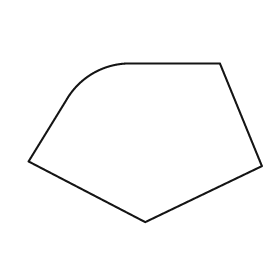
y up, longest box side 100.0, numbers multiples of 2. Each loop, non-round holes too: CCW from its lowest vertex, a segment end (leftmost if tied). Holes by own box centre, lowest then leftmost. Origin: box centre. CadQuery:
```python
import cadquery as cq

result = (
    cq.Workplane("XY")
    .moveTo(0.0, -34.0)
    .lineTo(50.0, -10.0)
    .lineTo(32.0, 34.0)
    .lineTo(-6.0, 34.0)
    .threePointArc((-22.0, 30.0), (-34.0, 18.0))
    .lineTo(-50.0, -8.0)
    .close()
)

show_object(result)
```